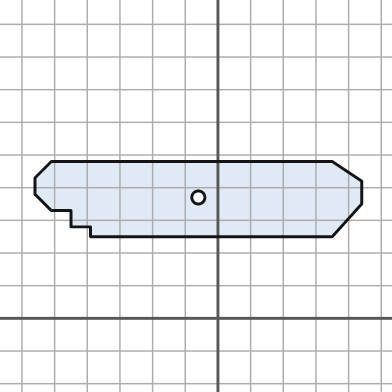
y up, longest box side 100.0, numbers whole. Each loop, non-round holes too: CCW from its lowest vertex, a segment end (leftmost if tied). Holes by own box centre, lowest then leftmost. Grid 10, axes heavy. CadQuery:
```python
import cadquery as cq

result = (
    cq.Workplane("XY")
    .moveTo(-39.0, 25.0)
    .lineTo(35.0, 25.0)
    .lineTo(44.0, 35.0)
    .lineTo(44.0, 42.0)
    .lineTo(35.0, 48.0)
    .lineTo(-51.0, 48.0)
    .lineTo(-56.0, 43.0)
    .lineTo(-56.0, 38.0)
    .lineTo(-51.0, 33.0)
    .lineTo(-45.0, 33.0)
    .lineTo(-45.0, 28.0)
    .lineTo(-39.0, 28.0)
    .close()
    .moveTo(-6.0, 37.0)
    .circle(2.0)
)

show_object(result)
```